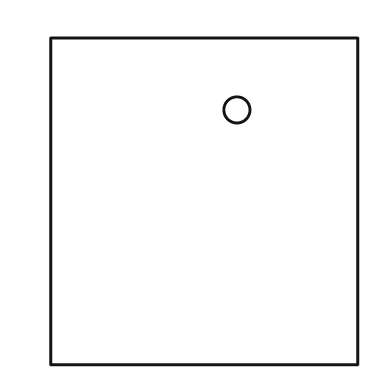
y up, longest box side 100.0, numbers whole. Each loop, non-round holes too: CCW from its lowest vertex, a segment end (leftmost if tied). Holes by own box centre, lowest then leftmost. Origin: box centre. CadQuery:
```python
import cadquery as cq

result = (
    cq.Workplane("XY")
    .moveTo(-47.0, -50.0)
    .lineTo(47.0, -50.0)
    .lineTo(47.0, 50.0)
    .lineTo(-47.0, 50.0)
    .close()
    .moveTo(10.0, 28.0)
    .circle(4.0)
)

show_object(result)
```